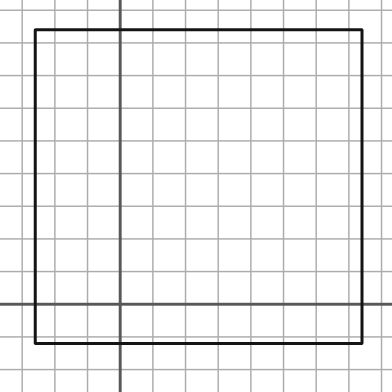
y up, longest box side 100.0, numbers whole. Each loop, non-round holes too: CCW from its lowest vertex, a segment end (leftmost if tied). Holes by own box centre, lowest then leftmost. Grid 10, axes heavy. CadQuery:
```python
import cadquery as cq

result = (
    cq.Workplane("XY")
    .moveTo(-26.0, -12.0)
    .lineTo(74.0, -12.0)
    .lineTo(74.0, 84.0)
    .lineTo(-26.0, 84.0)
    .close()
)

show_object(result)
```